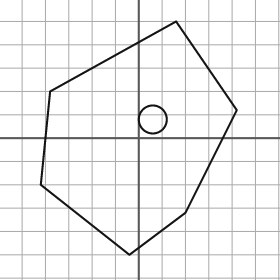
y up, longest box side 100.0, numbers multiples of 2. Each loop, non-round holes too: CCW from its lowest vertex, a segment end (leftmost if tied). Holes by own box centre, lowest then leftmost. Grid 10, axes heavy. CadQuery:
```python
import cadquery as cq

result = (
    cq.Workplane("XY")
    .moveTo(-4.0, -50.0)
    .lineTo(20.0, -32.0)
    .lineTo(42.0, 12.0)
    .lineTo(16.0, 50.0)
    .lineTo(-38.0, 20.0)
    .lineTo(-42.0, -20.0)
    .close()
    .moveTo(6.0, 8.0)
    .circle(6.0)
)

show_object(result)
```